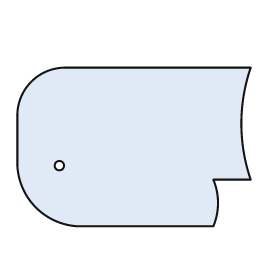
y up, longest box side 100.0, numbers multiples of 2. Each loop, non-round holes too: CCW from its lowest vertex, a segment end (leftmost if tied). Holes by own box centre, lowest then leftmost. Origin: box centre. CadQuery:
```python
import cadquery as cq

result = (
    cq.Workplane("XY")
    .moveTo(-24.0, -34.0)
    .lineTo(34.0, -34.0)
    .threePointArc((36.0, -24.0), (34.0, -14.0))
    .lineTo(50.0, -14.0)
    .threePointArc((46.0, 10.0), (50.0, 34.0))
    .lineTo(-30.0, 34.0)
    .threePointArc((-44.0, 28.0), (-50.0, 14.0))
    .lineTo(-50.0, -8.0)
    .threePointArc((-42.0, -26.0), (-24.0, -34.0))
    .close()
    .moveTo(-32.0, -8.0)
    .circle(2.0)
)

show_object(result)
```